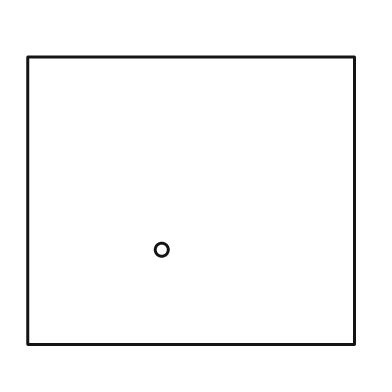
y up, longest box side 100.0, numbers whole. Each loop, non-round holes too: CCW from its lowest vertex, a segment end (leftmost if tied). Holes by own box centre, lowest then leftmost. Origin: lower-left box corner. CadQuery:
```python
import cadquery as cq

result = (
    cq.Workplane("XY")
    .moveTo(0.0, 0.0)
    .lineTo(100.0, 0.0)
    .lineTo(100.0, 88.0)
    .lineTo(0.0, 88.0)
    .close()
    .moveTo(41.0, 29.0)
    .circle(2.0)
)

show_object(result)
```